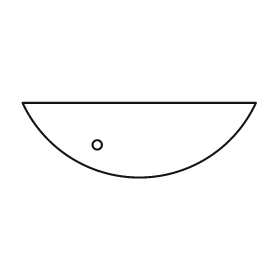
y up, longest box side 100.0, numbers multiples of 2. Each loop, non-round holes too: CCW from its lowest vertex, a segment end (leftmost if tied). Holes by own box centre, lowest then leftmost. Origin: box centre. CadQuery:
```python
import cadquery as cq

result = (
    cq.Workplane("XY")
    .moveTo(-50.0, 16.0)
    .threePointArc((0.0, -16.0), (50.0, 16.0))
    .close()
    .moveTo(-18.0, -2.0)
    .circle(2.0)
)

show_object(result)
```